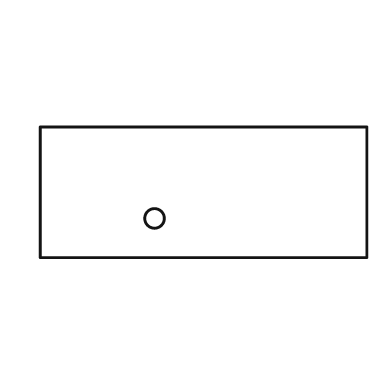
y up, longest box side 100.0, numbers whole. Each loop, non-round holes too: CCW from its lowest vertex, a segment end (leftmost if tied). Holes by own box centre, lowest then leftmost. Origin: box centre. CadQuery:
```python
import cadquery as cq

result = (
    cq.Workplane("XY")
    .moveTo(-50.0, -20.0)
    .lineTo(50.0, -20.0)
    .lineTo(50.0, 20.0)
    .lineTo(-50.0, 20.0)
    .close()
    .moveTo(-15.0, -8.0)
    .circle(3.0)
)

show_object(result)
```